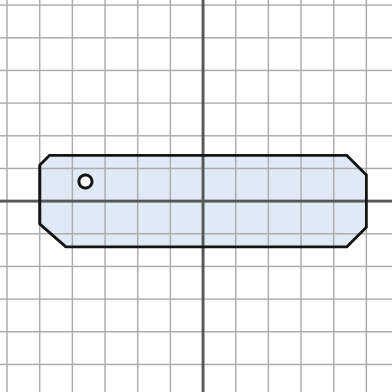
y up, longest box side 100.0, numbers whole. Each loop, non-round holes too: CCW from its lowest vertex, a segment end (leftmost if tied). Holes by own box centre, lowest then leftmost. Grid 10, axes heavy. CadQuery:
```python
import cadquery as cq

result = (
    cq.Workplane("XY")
    .moveTo(-42.0, -14.0)
    .lineTo(44.0, -14.0)
    .lineTo(50.0, -8.0)
    .lineTo(50.0, 8.0)
    .lineTo(44.0, 14.0)
    .lineTo(-47.0, 14.0)
    .lineTo(-50.0, 11.0)
    .lineTo(-50.0, -7.0)
    .close()
    .moveTo(-36.0, 6.0)
    .circle(2.0)
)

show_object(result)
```